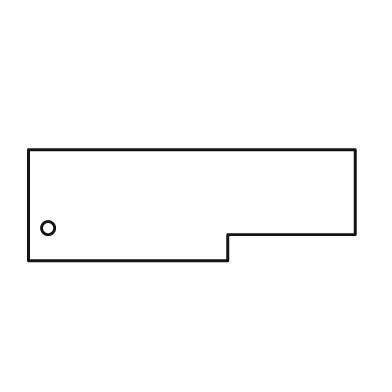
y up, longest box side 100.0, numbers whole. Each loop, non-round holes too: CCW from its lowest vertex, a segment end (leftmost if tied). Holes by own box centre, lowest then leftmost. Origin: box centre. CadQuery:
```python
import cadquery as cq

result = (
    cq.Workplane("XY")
    .moveTo(-50.0, -17.0)
    .lineTo(11.0, -17.0)
    .lineTo(11.0, -9.0)
    .lineTo(50.0, -9.0)
    .lineTo(50.0, 17.0)
    .lineTo(-50.0, 17.0)
    .close()
    .moveTo(-44.0, -7.0)
    .circle(2.0)
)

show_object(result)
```